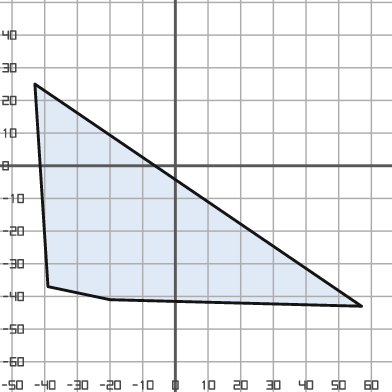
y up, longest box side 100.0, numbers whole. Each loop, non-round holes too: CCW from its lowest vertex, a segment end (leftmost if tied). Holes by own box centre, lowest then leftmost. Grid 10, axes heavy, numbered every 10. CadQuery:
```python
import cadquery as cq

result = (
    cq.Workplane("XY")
    .moveTo(57.0, -43.0)
    .lineTo(-43.0, 25.0)
    .lineTo(-39.0, -37.0)
    .lineTo(-20.0, -41.0)
    .close()
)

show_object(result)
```